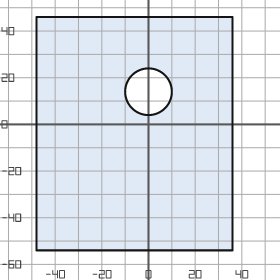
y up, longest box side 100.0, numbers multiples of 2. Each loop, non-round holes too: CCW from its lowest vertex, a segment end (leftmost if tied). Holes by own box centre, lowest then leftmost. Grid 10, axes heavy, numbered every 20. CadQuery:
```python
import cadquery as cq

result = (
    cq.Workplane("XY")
    .moveTo(-48.0, -54.0)
    .lineTo(36.0, -54.0)
    .lineTo(36.0, 46.0)
    .lineTo(-48.0, 46.0)
    .close()
    .moveTo(0.0, 14.0)
    .circle(10.0)
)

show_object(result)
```